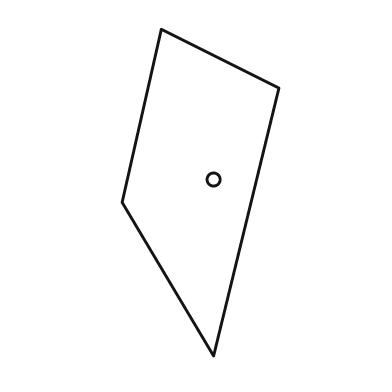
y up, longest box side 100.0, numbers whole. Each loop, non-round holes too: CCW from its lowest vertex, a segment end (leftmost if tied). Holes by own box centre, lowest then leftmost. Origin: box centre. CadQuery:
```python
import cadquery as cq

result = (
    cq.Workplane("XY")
    .moveTo(4.0, -50.0)
    .lineTo(24.0, 32.0)
    .lineTo(-12.0, 50.0)
    .lineTo(-24.0, -3.0)
    .close()
    .moveTo(4.0, 4.0)
    .circle(2.0)
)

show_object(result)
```